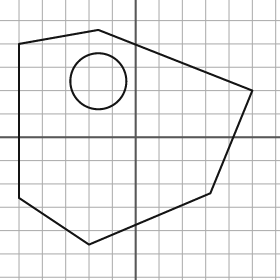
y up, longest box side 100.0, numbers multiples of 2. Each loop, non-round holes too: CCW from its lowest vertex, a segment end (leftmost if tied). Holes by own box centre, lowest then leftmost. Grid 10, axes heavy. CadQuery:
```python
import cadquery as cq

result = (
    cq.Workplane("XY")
    .moveTo(-20.0, -46.0)
    .lineTo(32.0, -24.0)
    .lineTo(50.0, 20.0)
    .lineTo(-16.0, 46.0)
    .lineTo(-50.0, 40.0)
    .lineTo(-50.0, -26.0)
    .close()
    .moveTo(-16.0, 24.0)
    .circle(12.0)
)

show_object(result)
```